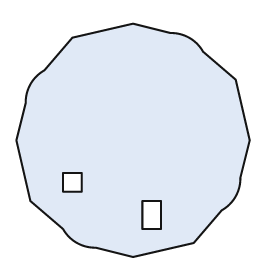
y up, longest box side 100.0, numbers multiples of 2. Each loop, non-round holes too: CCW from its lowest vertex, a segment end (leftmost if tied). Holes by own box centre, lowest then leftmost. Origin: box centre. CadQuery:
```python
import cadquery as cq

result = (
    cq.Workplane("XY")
    .moveTo(0.0, -50.0)
    .lineTo(26.0, -44.0)
    .lineTo(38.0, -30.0)
    .threePointArc((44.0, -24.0), (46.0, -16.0))
    .lineTo(50.0, 0.0)
    .lineTo(44.0, 26.0)
    .lineTo(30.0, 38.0)
    .threePointArc((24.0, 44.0), (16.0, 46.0))
    .lineTo(0.0, 50.0)
    .lineTo(-26.0, 44.0)
    .lineTo(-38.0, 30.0)
    .threePointArc((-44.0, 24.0), (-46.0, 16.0))
    .lineTo(-50.0, 0.0)
    .lineTo(-44.0, -26.0)
    .lineTo(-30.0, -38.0)
    .threePointArc((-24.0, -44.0), (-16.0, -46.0))
    .close()
    .moveTo(4.0, -38.0)
    .lineTo(12.0, -38.0)
    .lineTo(12.0, -26.0)
    .lineTo(4.0, -26.0)
    .close()
    .moveTo(-30.0, -22.0)
    .lineTo(-22.0, -22.0)
    .lineTo(-22.0, -14.0)
    .lineTo(-30.0, -14.0)
    .close()
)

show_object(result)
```